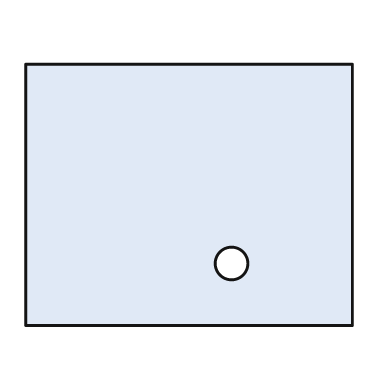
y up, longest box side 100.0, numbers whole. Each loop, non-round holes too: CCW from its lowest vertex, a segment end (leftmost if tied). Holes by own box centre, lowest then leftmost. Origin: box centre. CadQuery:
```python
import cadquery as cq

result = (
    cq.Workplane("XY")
    .moveTo(-50.0, -40.0)
    .lineTo(50.0, -40.0)
    .lineTo(50.0, 40.0)
    .lineTo(-50.0, 40.0)
    .close()
    .moveTo(13.0, -21.0)
    .circle(5.0)
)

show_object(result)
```